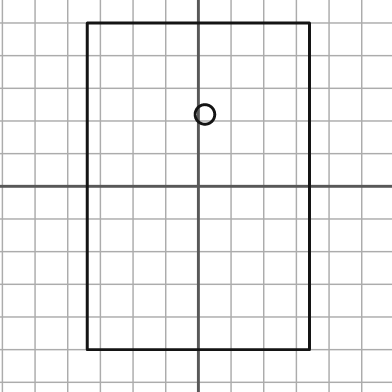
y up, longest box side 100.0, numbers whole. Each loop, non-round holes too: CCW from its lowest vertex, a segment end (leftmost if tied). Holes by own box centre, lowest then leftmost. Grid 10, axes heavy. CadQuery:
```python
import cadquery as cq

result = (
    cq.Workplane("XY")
    .moveTo(-34.0, -50.0)
    .lineTo(34.0, -50.0)
    .lineTo(34.0, 50.0)
    .lineTo(-34.0, 50.0)
    .close()
    .moveTo(2.0, 22.0)
    .circle(3.0)
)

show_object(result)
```